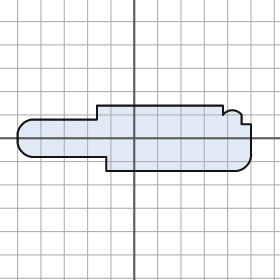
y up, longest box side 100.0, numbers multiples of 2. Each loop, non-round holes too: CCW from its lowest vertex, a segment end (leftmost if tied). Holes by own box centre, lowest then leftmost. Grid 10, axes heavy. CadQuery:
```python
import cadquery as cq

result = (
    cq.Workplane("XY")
    .moveTo(-12.0, -14.0)
    .lineTo(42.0, -14.0)
    .threePointArc((48.0, -12.0), (50.0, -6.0))
    .lineTo(50.0, 6.0)
    .lineTo(46.0, 6.0)
    .lineTo(46.0, 10.0)
    .threePointArc((42.0, 12.0), (38.0, 10.0))
    .lineTo(38.0, 14.0)
    .lineTo(-16.0, 14.0)
    .lineTo(-16.0, 8.0)
    .lineTo(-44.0, 8.0)
    .threePointArc((-48.0, 6.0), (-50.0, 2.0))
    .lineTo(-50.0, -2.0)
    .threePointArc((-48.0, -6.0), (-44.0, -8.0))
    .lineTo(-12.0, -8.0)
    .close()
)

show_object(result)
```